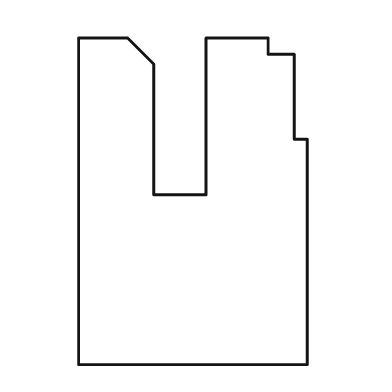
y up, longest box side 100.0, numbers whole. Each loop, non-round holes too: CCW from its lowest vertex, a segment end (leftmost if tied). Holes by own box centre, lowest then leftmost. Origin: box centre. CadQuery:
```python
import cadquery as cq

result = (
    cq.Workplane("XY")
    .moveTo(-35.0, -50.0)
    .lineTo(35.0, -50.0)
    .lineTo(35.0, 19.0)
    .lineTo(31.0, 19.0)
    .lineTo(31.0, 45.0)
    .lineTo(23.0, 45.0)
    .lineTo(23.0, 50.0)
    .lineTo(4.0, 50.0)
    .lineTo(4.0, 2.0)
    .lineTo(-12.0, 2.0)
    .lineTo(-12.0, 42.0)
    .lineTo(-20.0, 50.0)
    .lineTo(-35.0, 50.0)
    .close()
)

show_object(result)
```